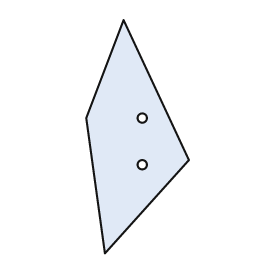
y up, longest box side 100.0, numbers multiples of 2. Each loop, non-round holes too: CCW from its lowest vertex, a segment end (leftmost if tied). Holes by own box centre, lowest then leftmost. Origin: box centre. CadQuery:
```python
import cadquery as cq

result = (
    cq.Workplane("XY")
    .moveTo(-14.0, -50.0)
    .lineTo(22.0, -10.0)
    .lineTo(-6.0, 50.0)
    .lineTo(-22.0, 8.0)
    .close()
    .moveTo(2.0, -12.0)
    .circle(2.0)
    .moveTo(2.0, 8.0)
    .circle(2.0)
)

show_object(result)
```